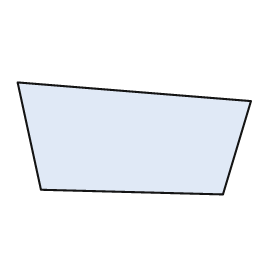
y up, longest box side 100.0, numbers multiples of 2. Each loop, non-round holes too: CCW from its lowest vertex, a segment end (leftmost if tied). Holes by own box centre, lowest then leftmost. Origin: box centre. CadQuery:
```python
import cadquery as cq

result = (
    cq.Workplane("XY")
    .moveTo(38.0, -24.0)
    .lineTo(50.0, 16.0)
    .lineTo(-50.0, 24.0)
    .lineTo(-40.0, -22.0)
    .close()
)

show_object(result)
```